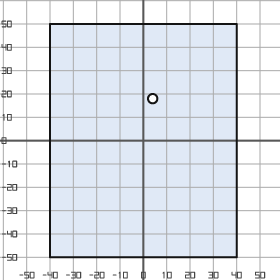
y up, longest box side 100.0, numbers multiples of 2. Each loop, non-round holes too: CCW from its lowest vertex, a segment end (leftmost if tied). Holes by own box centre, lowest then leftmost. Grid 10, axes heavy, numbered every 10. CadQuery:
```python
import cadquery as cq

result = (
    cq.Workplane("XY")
    .moveTo(-40.0, -50.0)
    .lineTo(40.0, -50.0)
    .lineTo(40.0, 50.0)
    .lineTo(-40.0, 50.0)
    .close()
    .moveTo(4.0, 18.0)
    .circle(2.0)
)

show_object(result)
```